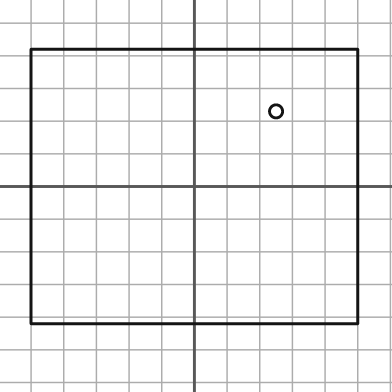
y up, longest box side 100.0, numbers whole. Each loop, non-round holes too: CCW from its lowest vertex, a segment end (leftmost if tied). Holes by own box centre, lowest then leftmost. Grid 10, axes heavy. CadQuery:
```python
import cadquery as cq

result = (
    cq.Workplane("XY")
    .moveTo(-50.0, -42.0)
    .lineTo(50.0, -42.0)
    .lineTo(50.0, 42.0)
    .lineTo(-50.0, 42.0)
    .close()
    .moveTo(25.0, 23.0)
    .circle(2.0)
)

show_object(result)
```